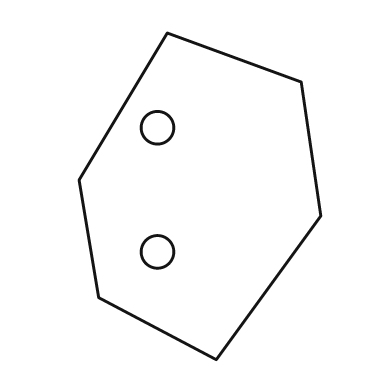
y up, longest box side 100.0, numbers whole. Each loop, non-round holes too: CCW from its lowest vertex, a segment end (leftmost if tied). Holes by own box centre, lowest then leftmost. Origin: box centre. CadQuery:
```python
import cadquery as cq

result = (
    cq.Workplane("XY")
    .moveTo(5.0, -50.0)
    .lineTo(37.0, -6.0)
    .lineTo(31.0, 35.0)
    .lineTo(-10.0, 50.0)
    .lineTo(-37.0, 5.0)
    .lineTo(-31.0, -31.0)
    .close()
    .moveTo(-13.0, -17.0)
    .circle(5.0)
    .moveTo(-13.0, 21.0)
    .circle(5.0)
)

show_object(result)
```